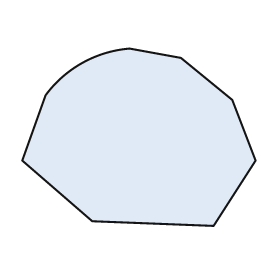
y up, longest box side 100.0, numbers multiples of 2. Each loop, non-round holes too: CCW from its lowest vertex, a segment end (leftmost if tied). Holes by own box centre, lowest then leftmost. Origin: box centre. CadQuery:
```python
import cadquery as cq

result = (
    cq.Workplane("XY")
    .moveTo(32.0, -38.0)
    .lineTo(50.0, -10.0)
    .lineTo(40.0, 16.0)
    .lineTo(18.0, 34.0)
    .lineTo(-4.0, 38.0)
    .threePointArc((-24.0, 32.0), (-40.0, 18.0))
    .lineTo(-50.0, -10.0)
    .lineTo(-20.0, -36.0)
    .close()
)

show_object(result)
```